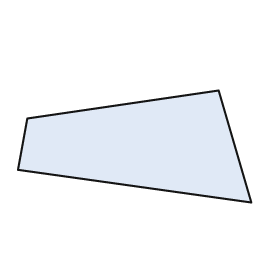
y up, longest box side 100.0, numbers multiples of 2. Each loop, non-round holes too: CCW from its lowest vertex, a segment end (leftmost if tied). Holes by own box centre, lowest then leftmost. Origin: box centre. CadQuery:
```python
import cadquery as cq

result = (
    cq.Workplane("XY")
    .moveTo(50.0, -24.0)
    .lineTo(36.0, 24.0)
    .lineTo(-46.0, 12.0)
    .lineTo(-50.0, -10.0)
    .close()
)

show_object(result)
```